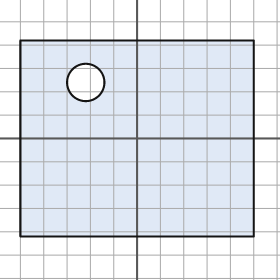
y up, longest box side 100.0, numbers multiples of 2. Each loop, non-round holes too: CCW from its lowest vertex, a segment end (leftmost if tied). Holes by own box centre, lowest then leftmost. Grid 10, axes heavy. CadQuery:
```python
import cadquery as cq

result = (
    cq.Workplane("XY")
    .moveTo(-50.0, -42.0)
    .lineTo(50.0, -42.0)
    .lineTo(50.0, 42.0)
    .lineTo(-50.0, 42.0)
    .close()
    .moveTo(-22.0, 24.0)
    .circle(8.0)
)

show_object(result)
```